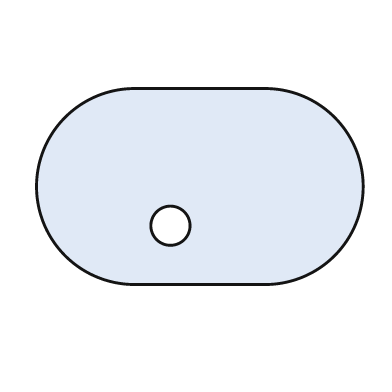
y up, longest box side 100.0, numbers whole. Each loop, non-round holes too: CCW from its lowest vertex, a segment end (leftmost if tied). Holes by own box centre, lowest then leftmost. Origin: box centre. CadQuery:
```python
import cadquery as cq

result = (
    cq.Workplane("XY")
    .moveTo(-20.0, -30.0)
    .lineTo(20.0, -30.0)
    .threePointArc((50.0, 0.0), (20.0, 30.0))
    .lineTo(-20.0, 30.0)
    .threePointArc((-50.0, 0.0), (-20.0, -30.0))
    .close()
    .moveTo(-9.0, -12.0)
    .circle(6.0)
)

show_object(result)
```